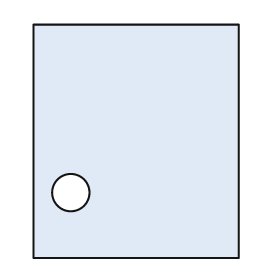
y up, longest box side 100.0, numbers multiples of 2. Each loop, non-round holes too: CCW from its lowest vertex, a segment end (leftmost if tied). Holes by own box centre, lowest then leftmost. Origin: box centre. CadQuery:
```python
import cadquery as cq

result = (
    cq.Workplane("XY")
    .moveTo(-44.0, -50.0)
    .lineTo(44.0, -50.0)
    .lineTo(44.0, 50.0)
    .lineTo(-44.0, 50.0)
    .close()
    .moveTo(-28.0, -22.0)
    .circle(8.0)
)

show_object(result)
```